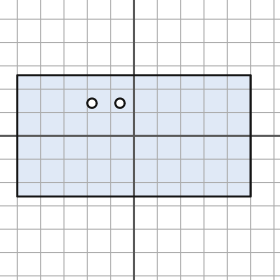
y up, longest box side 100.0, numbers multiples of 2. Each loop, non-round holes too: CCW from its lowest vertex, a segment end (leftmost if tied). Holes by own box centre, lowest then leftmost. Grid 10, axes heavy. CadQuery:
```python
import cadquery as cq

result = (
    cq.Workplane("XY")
    .moveTo(-50.0, -26.0)
    .lineTo(50.0, -26.0)
    .lineTo(50.0, 26.0)
    .lineTo(-50.0, 26.0)
    .close()
    .moveTo(-18.0, 14.0)
    .circle(2.0)
    .moveTo(-6.0, 14.0)
    .circle(2.0)
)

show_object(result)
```